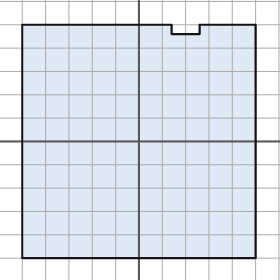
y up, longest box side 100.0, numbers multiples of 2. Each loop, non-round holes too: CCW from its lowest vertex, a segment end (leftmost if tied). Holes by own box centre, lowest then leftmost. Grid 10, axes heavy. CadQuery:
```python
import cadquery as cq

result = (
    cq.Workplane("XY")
    .moveTo(-50.0, -50.0)
    .lineTo(50.0, -50.0)
    .lineTo(50.0, 50.0)
    .lineTo(26.0, 50.0)
    .lineTo(26.0, 46.0)
    .lineTo(14.0, 46.0)
    .lineTo(14.0, 50.0)
    .lineTo(-50.0, 50.0)
    .close()
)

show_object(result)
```